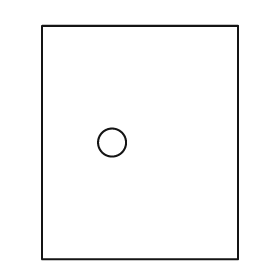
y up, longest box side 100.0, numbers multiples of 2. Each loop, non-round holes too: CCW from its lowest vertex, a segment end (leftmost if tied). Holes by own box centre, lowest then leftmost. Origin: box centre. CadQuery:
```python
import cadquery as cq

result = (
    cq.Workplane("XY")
    .moveTo(-42.0, -50.0)
    .lineTo(42.0, -50.0)
    .lineTo(42.0, 50.0)
    .lineTo(-42.0, 50.0)
    .close()
    .moveTo(-12.0, 0.0)
    .circle(6.0)
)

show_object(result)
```